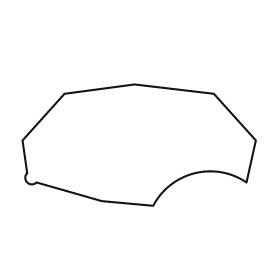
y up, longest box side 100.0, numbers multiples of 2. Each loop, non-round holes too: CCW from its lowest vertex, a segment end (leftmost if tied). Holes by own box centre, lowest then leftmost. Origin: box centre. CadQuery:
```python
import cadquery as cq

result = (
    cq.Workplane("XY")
    .moveTo(6.0, -26.0)
    .threePointArc((24.0, -12.0), (46.0, -16.0))
    .lineTo(50.0, 2.0)
    .lineTo(32.0, 22.0)
    .lineTo(-2.0, 26.0)
    .lineTo(-32.0, 22.0)
    .lineTo(-50.0, 2.0)
    .lineTo(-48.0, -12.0)
    .threePointArc((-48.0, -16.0), (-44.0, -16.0))
    .lineTo(-16.0, -24.0)
    .close()
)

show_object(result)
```